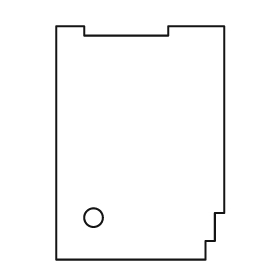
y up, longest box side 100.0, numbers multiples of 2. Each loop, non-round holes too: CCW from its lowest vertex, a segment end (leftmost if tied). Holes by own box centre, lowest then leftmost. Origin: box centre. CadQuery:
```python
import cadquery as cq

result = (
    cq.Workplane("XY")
    .moveTo(-36.0, -50.0)
    .lineTo(28.0, -50.0)
    .lineTo(28.0, -42.0)
    .lineTo(32.0, -42.0)
    .lineTo(32.0, -30.0)
    .lineTo(36.0, -30.0)
    .lineTo(36.0, 50.0)
    .lineTo(12.0, 50.0)
    .lineTo(12.0, 46.0)
    .lineTo(-24.0, 46.0)
    .lineTo(-24.0, 50.0)
    .lineTo(-36.0, 50.0)
    .close()
    .moveTo(-20.0, -32.0)
    .circle(4.0)
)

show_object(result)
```